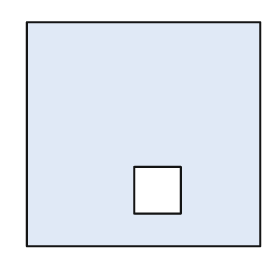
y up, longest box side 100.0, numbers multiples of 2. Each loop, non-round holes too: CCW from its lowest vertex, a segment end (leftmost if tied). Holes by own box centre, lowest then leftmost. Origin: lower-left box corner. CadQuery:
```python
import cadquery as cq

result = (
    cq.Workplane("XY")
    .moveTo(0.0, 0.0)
    .lineTo(100.0, 0.0)
    .lineTo(100.0, 96.0)
    .lineTo(0.0, 96.0)
    .close()
    .moveTo(46.0, 14.0)
    .lineTo(66.0, 14.0)
    .lineTo(66.0, 34.0)
    .lineTo(46.0, 34.0)
    .close()
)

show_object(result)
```